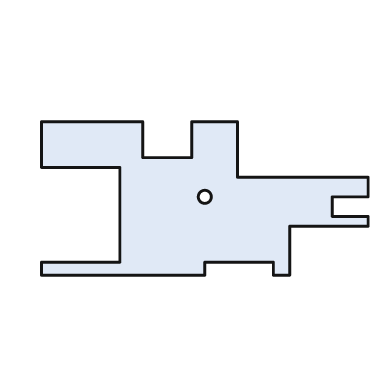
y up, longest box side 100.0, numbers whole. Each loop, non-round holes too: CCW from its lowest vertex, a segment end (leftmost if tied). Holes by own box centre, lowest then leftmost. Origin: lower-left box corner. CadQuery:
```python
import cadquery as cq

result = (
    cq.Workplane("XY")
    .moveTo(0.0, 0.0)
    .lineTo(50.0, 0.0)
    .lineTo(50.0, 4.0)
    .lineTo(71.0, 4.0)
    .lineTo(71.0, 0.0)
    .lineTo(76.0, 0.0)
    .lineTo(76.0, 15.0)
    .lineTo(100.0, 15.0)
    .lineTo(100.0, 18.0)
    .lineTo(89.0, 18.0)
    .lineTo(89.0, 24.0)
    .lineTo(100.0, 24.0)
    .lineTo(100.0, 30.0)
    .lineTo(60.0, 30.0)
    .lineTo(60.0, 47.0)
    .lineTo(46.0, 47.0)
    .lineTo(46.0, 36.0)
    .lineTo(31.0, 36.0)
    .lineTo(31.0, 47.0)
    .lineTo(0.0, 47.0)
    .lineTo(0.0, 33.0)
    .lineTo(24.0, 33.0)
    .lineTo(24.0, 4.0)
    .lineTo(0.0, 4.0)
    .close()
    .moveTo(50.0, 24.0)
    .circle(2.0)
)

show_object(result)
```